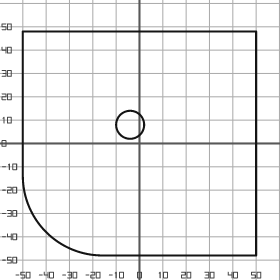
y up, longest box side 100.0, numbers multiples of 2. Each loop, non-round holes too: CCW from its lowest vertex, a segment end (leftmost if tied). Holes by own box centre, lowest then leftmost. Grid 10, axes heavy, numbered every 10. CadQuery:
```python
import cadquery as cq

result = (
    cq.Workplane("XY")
    .moveTo(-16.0, -48.0)
    .lineTo(50.0, -48.0)
    .lineTo(50.0, 48.0)
    .lineTo(-50.0, 48.0)
    .lineTo(-50.0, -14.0)
    .threePointArc((-40.0, -38.0), (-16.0, -48.0))
    .close()
    .moveTo(-4.0, 8.0)
    .circle(6.0)
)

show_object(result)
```